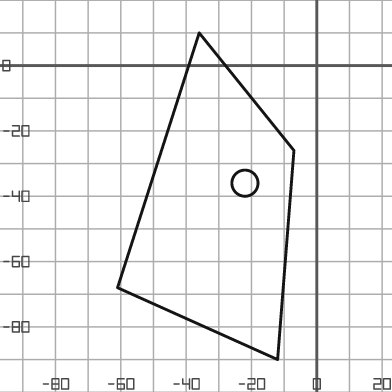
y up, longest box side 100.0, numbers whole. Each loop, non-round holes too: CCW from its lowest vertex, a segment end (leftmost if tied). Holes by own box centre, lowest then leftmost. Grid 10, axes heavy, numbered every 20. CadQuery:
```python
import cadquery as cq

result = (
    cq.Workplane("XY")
    .moveTo(-12.0, -90.0)
    .lineTo(-7.0, -26.0)
    .lineTo(-36.0, 10.0)
    .lineTo(-61.0, -68.0)
    .close()
    .moveTo(-22.0, -36.0)
    .circle(4.0)
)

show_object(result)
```